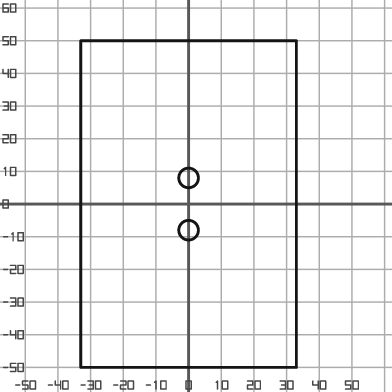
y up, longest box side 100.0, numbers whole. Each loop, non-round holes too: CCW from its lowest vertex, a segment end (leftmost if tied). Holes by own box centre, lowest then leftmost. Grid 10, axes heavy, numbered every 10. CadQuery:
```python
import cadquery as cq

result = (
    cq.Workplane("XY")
    .moveTo(-33.0, -50.0)
    .lineTo(33.0, -50.0)
    .lineTo(33.0, 50.0)
    .lineTo(-33.0, 50.0)
    .close()
    .moveTo(0.0, -8.0)
    .circle(3.0)
    .moveTo(0.0, 8.0)
    .circle(3.0)
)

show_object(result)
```